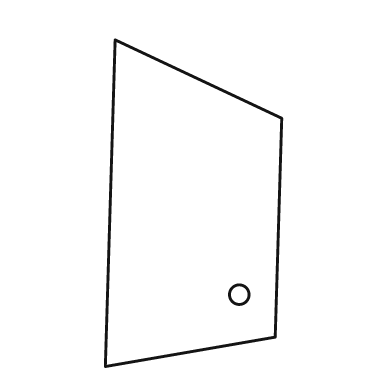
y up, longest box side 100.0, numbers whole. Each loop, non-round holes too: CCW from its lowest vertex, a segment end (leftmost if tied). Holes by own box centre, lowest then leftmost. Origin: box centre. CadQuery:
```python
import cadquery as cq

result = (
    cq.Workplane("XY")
    .moveTo(-27.0, -50.0)
    .lineTo(25.0, -41.0)
    .lineTo(27.0, 26.0)
    .lineTo(-24.0, 50.0)
    .close()
    .moveTo(14.0, -28.0)
    .circle(3.0)
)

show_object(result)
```